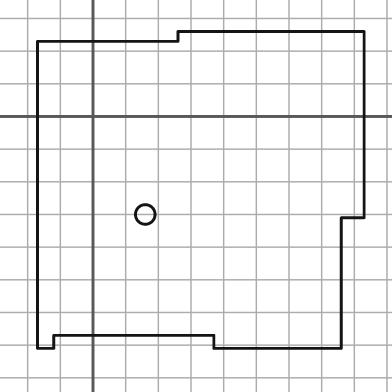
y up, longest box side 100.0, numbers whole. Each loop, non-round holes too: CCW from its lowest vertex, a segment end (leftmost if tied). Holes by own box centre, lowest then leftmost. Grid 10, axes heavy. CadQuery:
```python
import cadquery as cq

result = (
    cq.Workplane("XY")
    .moveTo(-17.0, -71.0)
    .lineTo(-12.0, -71.0)
    .lineTo(-12.0, -67.0)
    .lineTo(37.0, -67.0)
    .lineTo(37.0, -71.0)
    .lineTo(76.0, -71.0)
    .lineTo(76.0, -31.0)
    .lineTo(83.0, -31.0)
    .lineTo(83.0, 26.0)
    .lineTo(26.0, 26.0)
    .lineTo(26.0, 23.0)
    .lineTo(-17.0, 23.0)
    .close()
    .moveTo(16.0, -30.0)
    .circle(3.0)
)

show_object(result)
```